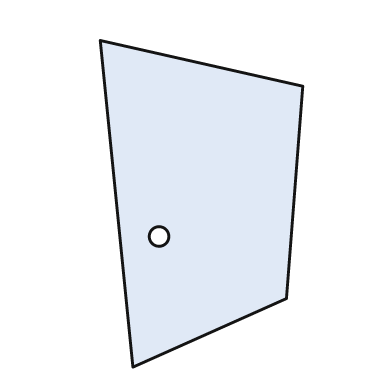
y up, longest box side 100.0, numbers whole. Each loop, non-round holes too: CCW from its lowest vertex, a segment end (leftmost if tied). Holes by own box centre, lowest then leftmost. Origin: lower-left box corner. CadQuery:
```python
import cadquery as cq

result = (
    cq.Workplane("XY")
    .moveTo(10.0, 0.0)
    .lineTo(57.0, 21.0)
    .lineTo(62.0, 86.0)
    .lineTo(0.0, 100.0)
    .close()
    .moveTo(18.0, 40.0)
    .circle(3.0)
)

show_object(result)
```